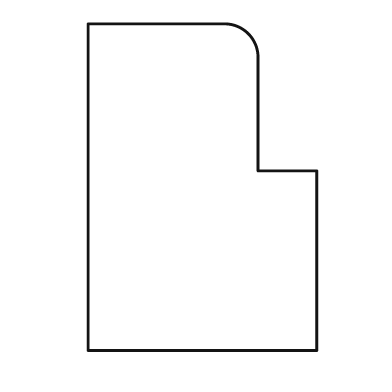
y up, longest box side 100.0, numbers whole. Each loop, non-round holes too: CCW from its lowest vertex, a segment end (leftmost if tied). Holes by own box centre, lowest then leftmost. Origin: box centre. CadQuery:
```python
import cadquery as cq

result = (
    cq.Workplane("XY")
    .moveTo(-35.0, -50.0)
    .lineTo(35.0, -50.0)
    .lineTo(35.0, 5.0)
    .lineTo(17.0, 5.0)
    .lineTo(17.0, 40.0)
    .threePointArc((14.0, 47.0), (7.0, 50.0))
    .lineTo(-35.0, 50.0)
    .close()
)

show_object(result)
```